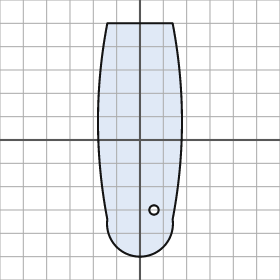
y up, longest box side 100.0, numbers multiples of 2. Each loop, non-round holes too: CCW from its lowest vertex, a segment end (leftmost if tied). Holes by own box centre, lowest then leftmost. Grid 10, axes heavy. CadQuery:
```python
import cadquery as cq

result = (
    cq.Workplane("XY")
    .moveTo(-14.0, -34.0)
    .threePointArc((0.0, -50.0), (14.0, -34.0))
    .threePointArc((18.0, 8.0), (14.0, 50.0))
    .lineTo(-14.0, 50.0)
    .threePointArc((-18.0, 8.0), (-14.0, -34.0))
    .close()
    .moveTo(6.0, -30.0)
    .circle(2.0)
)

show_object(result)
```